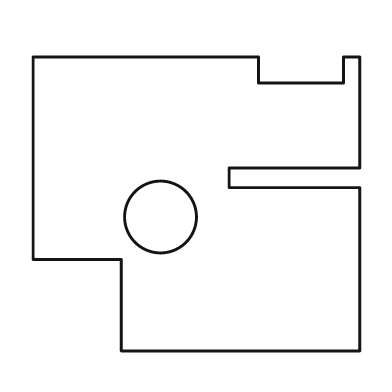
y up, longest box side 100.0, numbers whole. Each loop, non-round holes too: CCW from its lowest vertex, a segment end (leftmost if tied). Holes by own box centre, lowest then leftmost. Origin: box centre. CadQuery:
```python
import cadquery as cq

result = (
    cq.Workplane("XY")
    .moveTo(-23.0, -45.0)
    .lineTo(50.0, -45.0)
    .lineTo(50.0, 5.0)
    .lineTo(10.0, 5.0)
    .lineTo(10.0, 11.0)
    .lineTo(50.0, 11.0)
    .lineTo(50.0, 45.0)
    .lineTo(45.0, 45.0)
    .lineTo(45.0, 37.0)
    .lineTo(19.0, 37.0)
    .lineTo(19.0, 45.0)
    .lineTo(-50.0, 45.0)
    .lineTo(-50.0, -17.0)
    .lineTo(-23.0, -17.0)
    .close()
    .moveTo(-11.0, -4.0)
    .circle(11.0)
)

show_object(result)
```